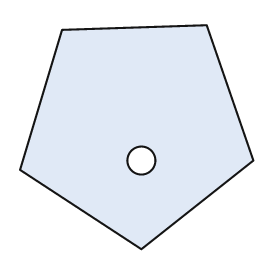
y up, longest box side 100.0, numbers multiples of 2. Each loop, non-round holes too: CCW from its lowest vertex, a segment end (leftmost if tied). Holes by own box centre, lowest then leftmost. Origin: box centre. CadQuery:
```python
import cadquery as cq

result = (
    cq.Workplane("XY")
    .moveTo(2.0, -48.0)
    .lineTo(50.0, -10.0)
    .lineTo(30.0, 48.0)
    .lineTo(-32.0, 46.0)
    .lineTo(-50.0, -14.0)
    .close()
    .moveTo(2.0, -10.0)
    .circle(6.0)
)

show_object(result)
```